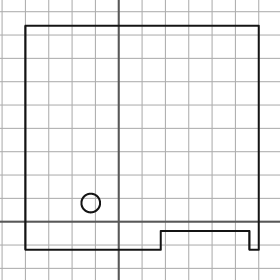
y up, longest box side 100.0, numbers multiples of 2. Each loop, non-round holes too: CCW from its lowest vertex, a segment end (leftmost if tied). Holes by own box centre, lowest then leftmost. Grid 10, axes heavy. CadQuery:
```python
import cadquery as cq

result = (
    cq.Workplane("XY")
    .moveTo(-40.0, -12.0)
    .lineTo(18.0, -12.0)
    .lineTo(18.0, -4.0)
    .lineTo(56.0, -4.0)
    .lineTo(56.0, -12.0)
    .lineTo(60.0, -12.0)
    .lineTo(60.0, 84.0)
    .lineTo(-40.0, 84.0)
    .close()
    .moveTo(-12.0, 8.0)
    .circle(4.0)
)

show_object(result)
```